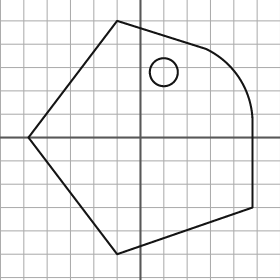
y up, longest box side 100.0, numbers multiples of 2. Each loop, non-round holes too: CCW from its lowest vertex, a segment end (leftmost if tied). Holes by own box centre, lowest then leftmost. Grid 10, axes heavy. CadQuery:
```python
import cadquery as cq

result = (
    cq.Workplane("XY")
    .moveTo(-10.0, -50.0)
    .lineTo(48.0, -30.0)
    .lineTo(48.0, 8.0)
    .threePointArc((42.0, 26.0), (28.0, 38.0))
    .lineTo(-10.0, 50.0)
    .lineTo(-48.0, 0.0)
    .close()
    .moveTo(10.0, 28.0)
    .circle(6.0)
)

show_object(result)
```